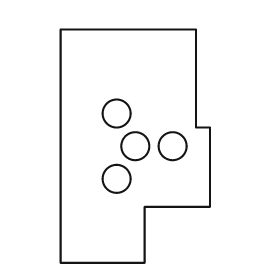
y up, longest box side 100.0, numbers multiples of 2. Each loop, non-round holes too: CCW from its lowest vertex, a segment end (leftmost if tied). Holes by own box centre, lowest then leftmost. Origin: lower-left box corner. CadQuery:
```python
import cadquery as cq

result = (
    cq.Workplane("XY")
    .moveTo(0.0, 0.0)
    .lineTo(36.0, 0.0)
    .lineTo(36.0, 24.0)
    .lineTo(64.0, 24.0)
    .lineTo(64.0, 58.0)
    .lineTo(58.0, 58.0)
    .lineTo(58.0, 100.0)
    .lineTo(0.0, 100.0)
    .close()
    .moveTo(24.0, 36.0)
    .circle(6.0)
    .moveTo(32.0, 50.0)
    .circle(6.0)
    .moveTo(48.0, 50.0)
    .circle(6.0)
    .moveTo(24.0, 64.0)
    .circle(6.0)
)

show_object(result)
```